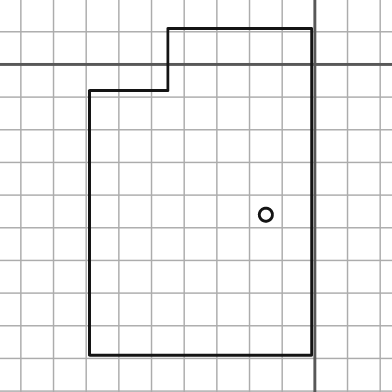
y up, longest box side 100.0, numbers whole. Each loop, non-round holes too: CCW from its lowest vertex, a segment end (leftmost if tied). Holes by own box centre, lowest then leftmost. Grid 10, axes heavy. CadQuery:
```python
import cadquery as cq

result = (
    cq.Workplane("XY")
    .moveTo(-69.0, -89.0)
    .lineTo(-1.0, -89.0)
    .lineTo(-1.0, 11.0)
    .lineTo(-45.0, 11.0)
    .lineTo(-45.0, -8.0)
    .lineTo(-69.0, -8.0)
    .close()
    .moveTo(-15.0, -46.0)
    .circle(2.0)
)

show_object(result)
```